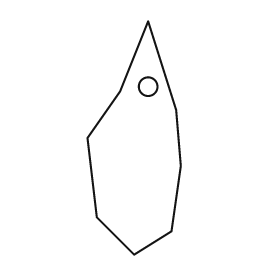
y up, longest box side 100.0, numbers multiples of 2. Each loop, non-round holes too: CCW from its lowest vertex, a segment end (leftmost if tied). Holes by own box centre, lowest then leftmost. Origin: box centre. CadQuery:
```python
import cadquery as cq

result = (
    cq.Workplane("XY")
    .moveTo(0.0, -50.0)
    .lineTo(16.0, -40.0)
    .lineTo(20.0, -12.0)
    .lineTo(18.0, 12.0)
    .lineTo(6.0, 50.0)
    .lineTo(-6.0, 20.0)
    .lineTo(-20.0, 0.0)
    .lineTo(-16.0, -34.0)
    .close()
    .moveTo(6.0, 22.0)
    .circle(4.0)
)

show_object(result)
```